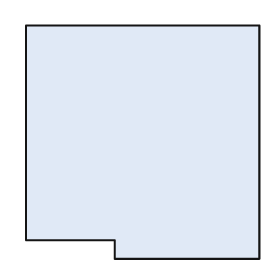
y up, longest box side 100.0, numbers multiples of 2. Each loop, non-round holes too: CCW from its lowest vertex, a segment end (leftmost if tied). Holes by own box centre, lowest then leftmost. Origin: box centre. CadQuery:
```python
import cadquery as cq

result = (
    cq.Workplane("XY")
    .moveTo(-12.0, -50.0)
    .lineTo(50.0, -50.0)
    .lineTo(50.0, 50.0)
    .lineTo(-50.0, 50.0)
    .lineTo(-50.0, -42.0)
    .lineTo(-12.0, -42.0)
    .close()
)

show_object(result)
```